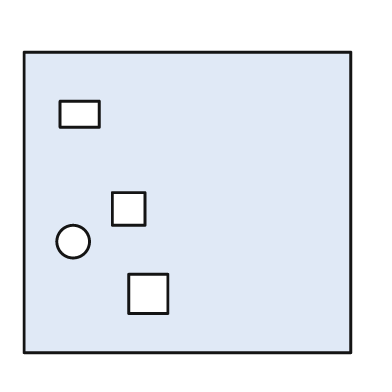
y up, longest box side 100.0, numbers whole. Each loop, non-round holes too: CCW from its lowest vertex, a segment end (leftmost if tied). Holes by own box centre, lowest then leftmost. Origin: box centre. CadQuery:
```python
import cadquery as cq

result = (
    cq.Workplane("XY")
    .moveTo(-50.0, -46.0)
    .lineTo(50.0, -46.0)
    .lineTo(50.0, 46.0)
    .lineTo(-50.0, 46.0)
    .close()
    .moveTo(-18.0, -34.0)
    .lineTo(-6.0, -34.0)
    .lineTo(-6.0, -22.0)
    .lineTo(-18.0, -22.0)
    .close()
    .moveTo(-35.0, -12.0)
    .circle(5.0)
    .moveTo(-23.0, -7.0)
    .lineTo(-13.0, -7.0)
    .lineTo(-13.0, 3.0)
    .lineTo(-23.0, 3.0)
    .close()
    .moveTo(-39.0, 23.0)
    .lineTo(-27.0, 23.0)
    .lineTo(-27.0, 31.0)
    .lineTo(-39.0, 31.0)
    .close()
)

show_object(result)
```